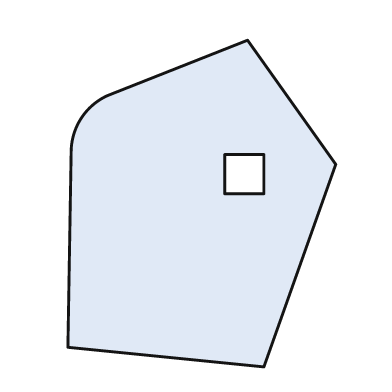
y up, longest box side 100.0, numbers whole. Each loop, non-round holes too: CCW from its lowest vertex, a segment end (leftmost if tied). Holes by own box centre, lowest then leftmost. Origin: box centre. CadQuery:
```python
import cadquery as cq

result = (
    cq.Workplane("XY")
    .moveTo(19.0, -50.0)
    .lineTo(41.0, 12.0)
    .lineTo(14.0, 50.0)
    .lineTo(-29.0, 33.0)
    .threePointArc((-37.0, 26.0), (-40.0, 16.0))
    .lineTo(-41.0, -44.0)
    .close()
    .moveTo(7.0, 3.0)
    .lineTo(19.0, 3.0)
    .lineTo(19.0, 15.0)
    .lineTo(7.0, 15.0)
    .close()
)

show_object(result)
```